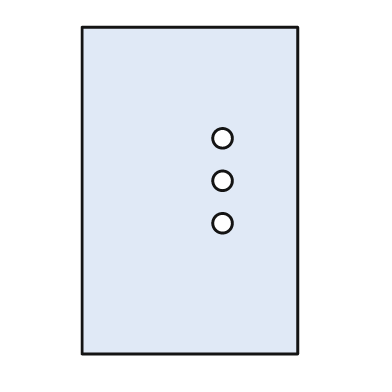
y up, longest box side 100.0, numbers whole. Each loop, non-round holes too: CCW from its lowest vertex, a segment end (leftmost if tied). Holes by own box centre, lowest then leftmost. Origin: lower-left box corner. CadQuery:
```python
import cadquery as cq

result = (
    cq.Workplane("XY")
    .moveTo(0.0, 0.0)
    .lineTo(66.0, 0.0)
    .lineTo(66.0, 100.0)
    .lineTo(0.0, 100.0)
    .close()
    .moveTo(43.0, 40.0)
    .circle(3.0)
    .moveTo(43.0, 53.0)
    .circle(3.0)
    .moveTo(43.0, 66.0)
    .circle(3.0)
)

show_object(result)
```